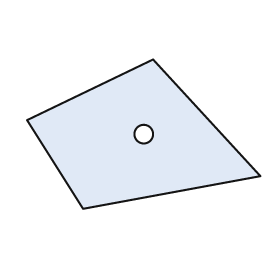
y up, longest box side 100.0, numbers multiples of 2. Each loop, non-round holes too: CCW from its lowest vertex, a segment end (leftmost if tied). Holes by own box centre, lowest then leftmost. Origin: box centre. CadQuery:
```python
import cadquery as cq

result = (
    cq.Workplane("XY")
    .moveTo(-26.0, -32.0)
    .lineTo(50.0, -18.0)
    .lineTo(4.0, 32.0)
    .lineTo(-50.0, 6.0)
    .close()
    .moveTo(0.0, 0.0)
    .circle(4.0)
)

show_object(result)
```